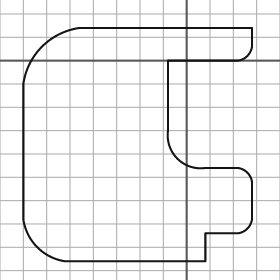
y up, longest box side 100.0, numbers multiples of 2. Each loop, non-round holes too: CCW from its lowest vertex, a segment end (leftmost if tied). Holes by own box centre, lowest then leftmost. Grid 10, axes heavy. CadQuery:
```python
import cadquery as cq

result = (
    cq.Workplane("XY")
    .moveTo(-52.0, -86.0)
    .lineTo(8.0, -86.0)
    .lineTo(8.0, -74.0)
    .lineTo(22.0, -74.0)
    .threePointArc((26.0, -72.0), (28.0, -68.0))
    .lineTo(28.0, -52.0)
    .threePointArc((26.0, -48.0), (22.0, -46.0))
    .lineTo(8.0, -46.0)
    .threePointArc((-4.0, -42.0), (-8.0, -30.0))
    .lineTo(-8.0, 0.0)
    .lineTo(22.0, 0.0)
    .threePointArc((26.0, 2.0), (28.0, 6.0))
    .lineTo(28.0, 14.0)
    .lineTo(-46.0, 14.0)
    .threePointArc((-62.0, 6.0), (-70.0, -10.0))
    .lineTo(-70.0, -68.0)
    .threePointArc((-64.0, -80.0), (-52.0, -86.0))
    .close()
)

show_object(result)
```